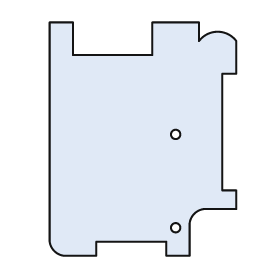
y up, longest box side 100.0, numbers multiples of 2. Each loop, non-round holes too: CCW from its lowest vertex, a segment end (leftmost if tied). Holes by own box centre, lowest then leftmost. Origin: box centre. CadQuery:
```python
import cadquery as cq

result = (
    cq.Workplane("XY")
    .moveTo(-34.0, -50.0)
    .lineTo(-20.0, -50.0)
    .lineTo(-20.0, -44.0)
    .lineTo(10.0, -44.0)
    .lineTo(10.0, -50.0)
    .lineTo(20.0, -50.0)
    .lineTo(20.0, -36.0)
    .threePointArc((22.0, -32.0), (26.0, -30.0))
    .lineTo(40.0, -30.0)
    .lineTo(40.0, -22.0)
    .lineTo(34.0, -22.0)
    .lineTo(34.0, 28.0)
    .lineTo(40.0, 28.0)
    .lineTo(40.0, 42.0)
    .threePointArc((32.0, 46.0), (24.0, 42.0))
    .lineTo(24.0, 50.0)
    .lineTo(4.0, 50.0)
    .lineTo(4.0, 36.0)
    .lineTo(-30.0, 36.0)
    .lineTo(-30.0, 50.0)
    .lineTo(-40.0, 50.0)
    .lineTo(-40.0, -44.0)
    .threePointArc((-38.0, -48.0), (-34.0, -50.0))
    .close()
    .moveTo(14.0, -38.0)
    .circle(2.0)
    .moveTo(14.0, 2.0)
    .circle(2.0)
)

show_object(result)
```